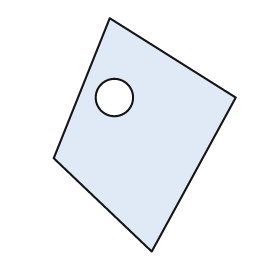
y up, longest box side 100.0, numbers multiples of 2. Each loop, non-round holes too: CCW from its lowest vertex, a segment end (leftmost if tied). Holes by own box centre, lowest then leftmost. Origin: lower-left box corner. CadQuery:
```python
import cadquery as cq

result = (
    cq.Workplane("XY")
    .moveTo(42.0, 0.0)
    .lineTo(78.0, 66.0)
    .lineTo(24.0, 100.0)
    .lineTo(0.0, 40.0)
    .close()
    .moveTo(26.0, 66.0)
    .circle(8.0)
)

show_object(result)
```